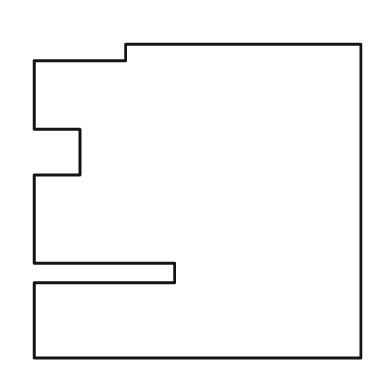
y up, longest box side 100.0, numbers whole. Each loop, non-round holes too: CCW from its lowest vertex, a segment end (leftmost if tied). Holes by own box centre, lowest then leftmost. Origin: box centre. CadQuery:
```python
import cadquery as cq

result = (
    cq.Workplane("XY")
    .moveTo(-50.0, -48.0)
    .lineTo(50.0, -48.0)
    .lineTo(50.0, 48.0)
    .lineTo(-22.0, 48.0)
    .lineTo(-22.0, 43.0)
    .lineTo(-50.0, 43.0)
    .lineTo(-50.0, 22.0)
    .lineTo(-36.0, 22.0)
    .lineTo(-36.0, 8.0)
    .lineTo(-50.0, 8.0)
    .lineTo(-50.0, -19.0)
    .lineTo(-7.0, -19.0)
    .lineTo(-7.0, -25.0)
    .lineTo(-50.0, -25.0)
    .close()
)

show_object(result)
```